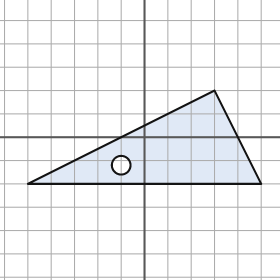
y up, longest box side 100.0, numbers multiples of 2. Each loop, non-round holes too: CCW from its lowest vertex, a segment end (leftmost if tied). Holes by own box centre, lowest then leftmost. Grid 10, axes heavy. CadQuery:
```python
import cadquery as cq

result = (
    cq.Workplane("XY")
    .moveTo(-50.0, -20.0)
    .lineTo(50.0, -20.0)
    .lineTo(30.0, 20.0)
    .close()
    .moveTo(-10.0, -12.0)
    .circle(4.0)
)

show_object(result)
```